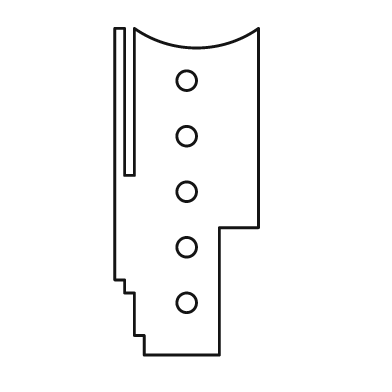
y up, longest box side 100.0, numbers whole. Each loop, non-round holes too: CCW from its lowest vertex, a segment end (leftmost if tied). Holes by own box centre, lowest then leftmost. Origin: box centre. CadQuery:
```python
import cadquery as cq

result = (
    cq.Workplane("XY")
    .moveTo(-13.0, -50.0)
    .lineTo(10.0, -50.0)
    .lineTo(10.0, -11.0)
    .lineTo(22.0, -11.0)
    .lineTo(22.0, 50.0)
    .threePointArc((3.0, 44.0), (-16.0, 50.0))
    .lineTo(-16.0, 5.0)
    .lineTo(-19.0, 5.0)
    .lineTo(-19.0, 50.0)
    .lineTo(-22.0, 50.0)
    .lineTo(-22.0, -27.0)
    .lineTo(-19.0, -27.0)
    .lineTo(-19.0, -31.0)
    .lineTo(-16.0, -31.0)
    .lineTo(-16.0, -44.0)
    .lineTo(-13.0, -44.0)
    .close()
    .moveTo(0.0, -34.0)
    .circle(3.0)
    .moveTo(0.0, -17.0)
    .circle(3.0)
    .moveTo(0.0, 0.0)
    .circle(3.0)
    .moveTo(0.0, 17.0)
    .circle(3.0)
    .moveTo(0.0, 34.0)
    .circle(3.0)
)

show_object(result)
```